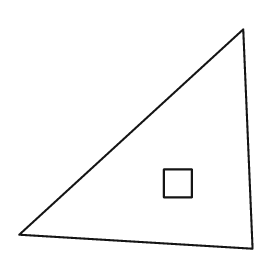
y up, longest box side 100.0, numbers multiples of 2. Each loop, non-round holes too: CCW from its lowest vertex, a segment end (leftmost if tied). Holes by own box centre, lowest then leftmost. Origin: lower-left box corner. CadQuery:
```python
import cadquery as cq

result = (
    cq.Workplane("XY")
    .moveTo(100.0, 0.0)
    .lineTo(96.0, 94.0)
    .lineTo(0.0, 6.0)
    .close()
    .moveTo(62.0, 22.0)
    .lineTo(74.0, 22.0)
    .lineTo(74.0, 34.0)
    .lineTo(62.0, 34.0)
    .close()
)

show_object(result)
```